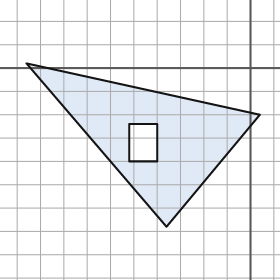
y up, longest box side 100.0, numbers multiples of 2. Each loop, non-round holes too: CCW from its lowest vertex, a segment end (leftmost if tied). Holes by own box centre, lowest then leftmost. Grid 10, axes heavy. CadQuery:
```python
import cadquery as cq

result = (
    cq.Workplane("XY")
    .moveTo(-36.0, -68.0)
    .lineTo(4.0, -20.0)
    .lineTo(-96.0, 2.0)
    .close()
    .moveTo(-52.0, -40.0)
    .lineTo(-40.0, -40.0)
    .lineTo(-40.0, -24.0)
    .lineTo(-52.0, -24.0)
    .close()
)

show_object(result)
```